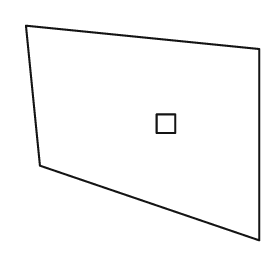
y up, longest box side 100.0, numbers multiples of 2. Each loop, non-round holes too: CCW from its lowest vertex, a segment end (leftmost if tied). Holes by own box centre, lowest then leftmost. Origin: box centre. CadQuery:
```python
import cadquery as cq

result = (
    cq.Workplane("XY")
    .moveTo(50.0, -46.0)
    .lineTo(50.0, 36.0)
    .lineTo(-50.0, 46.0)
    .lineTo(-44.0, -14.0)
    .close()
    .moveTo(6.0, 0.0)
    .lineTo(14.0, 0.0)
    .lineTo(14.0, 8.0)
    .lineTo(6.0, 8.0)
    .close()
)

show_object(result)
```